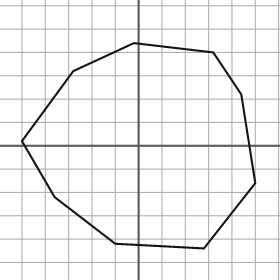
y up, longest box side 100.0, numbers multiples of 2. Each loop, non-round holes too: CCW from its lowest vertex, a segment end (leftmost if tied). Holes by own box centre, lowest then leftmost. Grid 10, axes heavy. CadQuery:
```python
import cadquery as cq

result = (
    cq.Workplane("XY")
    .moveTo(28.0, -44.0)
    .lineTo(50.0, -16.0)
    .lineTo(44.0, 22.0)
    .lineTo(32.0, 40.0)
    .lineTo(-2.0, 44.0)
    .lineTo(-28.0, 32.0)
    .lineTo(-50.0, 2.0)
    .lineTo(-36.0, -22.0)
    .lineTo(-10.0, -42.0)
    .close()
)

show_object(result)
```